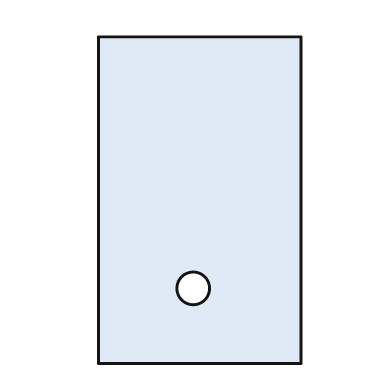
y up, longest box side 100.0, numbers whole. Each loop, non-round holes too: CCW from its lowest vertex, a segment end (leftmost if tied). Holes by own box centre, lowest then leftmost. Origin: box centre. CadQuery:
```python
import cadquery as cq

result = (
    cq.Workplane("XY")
    .moveTo(-31.0, -50.0)
    .lineTo(31.0, -50.0)
    .lineTo(31.0, 50.0)
    .lineTo(-31.0, 50.0)
    .close()
    .moveTo(-2.0, -27.0)
    .circle(5.0)
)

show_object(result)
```